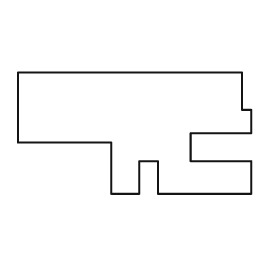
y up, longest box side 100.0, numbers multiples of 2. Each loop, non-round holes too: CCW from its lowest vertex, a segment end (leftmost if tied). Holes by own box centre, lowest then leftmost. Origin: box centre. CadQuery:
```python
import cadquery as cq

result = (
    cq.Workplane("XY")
    .moveTo(-10.0, -26.0)
    .lineTo(2.0, -26.0)
    .lineTo(2.0, -12.0)
    .lineTo(10.0, -12.0)
    .lineTo(10.0, -26.0)
    .lineTo(50.0, -26.0)
    .lineTo(50.0, -12.0)
    .lineTo(24.0, -12.0)
    .lineTo(24.0, 0.0)
    .lineTo(50.0, 0.0)
    .lineTo(50.0, 10.0)
    .lineTo(46.0, 10.0)
    .lineTo(46.0, 26.0)
    .lineTo(-50.0, 26.0)
    .lineTo(-50.0, -4.0)
    .lineTo(-10.0, -4.0)
    .close()
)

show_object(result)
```